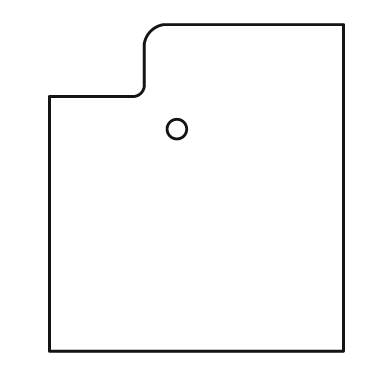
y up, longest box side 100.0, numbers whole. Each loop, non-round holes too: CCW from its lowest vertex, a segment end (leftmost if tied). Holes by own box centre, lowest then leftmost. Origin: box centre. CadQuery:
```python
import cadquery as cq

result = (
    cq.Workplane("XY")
    .moveTo(-45.0, -50.0)
    .lineTo(45.0, -50.0)
    .lineTo(45.0, 50.0)
    .lineTo(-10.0, 50.0)
    .threePointArc((-14.0, 48.0), (-16.0, 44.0))
    .lineTo(-16.0, 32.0)
    .threePointArc((-17.0, 29.0), (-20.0, 28.0))
    .lineTo(-45.0, 28.0)
    .close()
    .moveTo(-6.0, 18.0)
    .circle(3.0)
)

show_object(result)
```